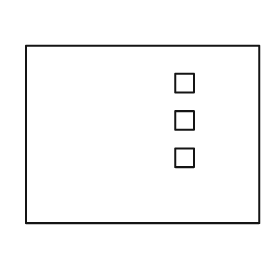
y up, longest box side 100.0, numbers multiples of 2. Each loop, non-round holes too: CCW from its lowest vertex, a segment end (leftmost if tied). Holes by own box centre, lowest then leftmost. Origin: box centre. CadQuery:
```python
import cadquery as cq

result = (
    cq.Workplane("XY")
    .moveTo(-50.0, -38.0)
    .lineTo(50.0, -38.0)
    .lineTo(50.0, 38.0)
    .lineTo(-50.0, 38.0)
    .close()
    .moveTo(14.0, -14.0)
    .lineTo(22.0, -14.0)
    .lineTo(22.0, -6.0)
    .lineTo(14.0, -6.0)
    .close()
    .moveTo(14.0, 2.0)
    .lineTo(22.0, 2.0)
    .lineTo(22.0, 10.0)
    .lineTo(14.0, 10.0)
    .close()
    .moveTo(14.0, 18.0)
    .lineTo(22.0, 18.0)
    .lineTo(22.0, 26.0)
    .lineTo(14.0, 26.0)
    .close()
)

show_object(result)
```